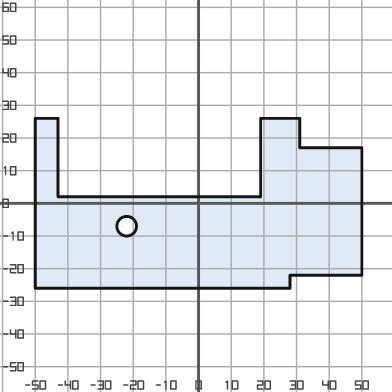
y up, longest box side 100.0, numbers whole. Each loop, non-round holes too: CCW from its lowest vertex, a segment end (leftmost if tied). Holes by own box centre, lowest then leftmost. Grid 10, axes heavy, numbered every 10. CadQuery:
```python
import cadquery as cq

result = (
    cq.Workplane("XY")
    .moveTo(-50.0, -26.0)
    .lineTo(28.0, -26.0)
    .lineTo(28.0, -22.0)
    .lineTo(50.0, -22.0)
    .lineTo(50.0, 17.0)
    .lineTo(31.0, 17.0)
    .lineTo(31.0, 26.0)
    .lineTo(19.0, 26.0)
    .lineTo(19.0, 2.0)
    .lineTo(-43.0, 2.0)
    .lineTo(-43.0, 26.0)
    .lineTo(-50.0, 26.0)
    .close()
    .moveTo(-22.0, -7.0)
    .circle(3.0)
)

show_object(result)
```